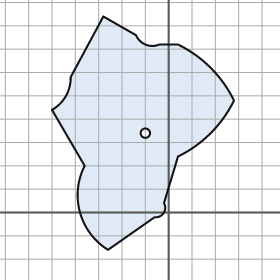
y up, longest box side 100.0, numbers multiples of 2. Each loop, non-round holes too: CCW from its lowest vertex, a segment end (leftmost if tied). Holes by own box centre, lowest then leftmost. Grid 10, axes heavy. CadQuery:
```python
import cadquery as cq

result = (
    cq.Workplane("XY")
    .moveTo(-26.0, -16.0)
    .lineTo(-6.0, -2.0)
    .threePointArc((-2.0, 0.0), (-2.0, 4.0))
    .lineTo(4.0, 24.0)
    .threePointArc((18.0, 34.0), (28.0, 48.0))
    .threePointArc((18.0, 62.0), (4.0, 72.0))
    .lineTo(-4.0, 72.0)
    .threePointArc((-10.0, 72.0), (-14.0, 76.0))
    .lineTo(-28.0, 84.0)
    .lineTo(-42.0, 58.0)
    .threePointArc((-44.0, 50.0), (-50.0, 44.0))
    .lineTo(-36.0, 20.0)
    .threePointArc((-38.0, 0.0), (-26.0, -16.0))
    .close()
    .moveTo(-10.0, 34.0)
    .circle(2.0)
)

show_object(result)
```